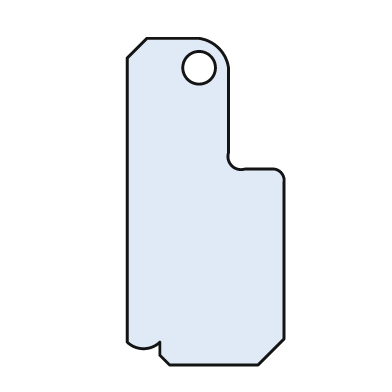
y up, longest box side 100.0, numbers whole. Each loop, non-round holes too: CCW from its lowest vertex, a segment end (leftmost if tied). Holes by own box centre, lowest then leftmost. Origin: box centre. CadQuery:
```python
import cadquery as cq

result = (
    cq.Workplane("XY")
    .moveTo(-11.0, -50.0)
    .lineTo(16.0, -50.0)
    .lineTo(24.0, -42.0)
    .lineTo(24.0, 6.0)
    .threePointArc((23.0, 9.0), (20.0, 10.0))
    .lineTo(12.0, 10.0)
    .threePointArc((8.0, 11.0), (7.0, 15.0))
    .lineTo(7.0, 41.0)
    .threePointArc((4.0, 47.0), (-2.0, 50.0))
    .lineTo(-18.0, 50.0)
    .lineTo(-24.0, 44.0)
    .lineTo(-24.0, -43.0)
    .threePointArc((-19.0, -45.0), (-14.0, -43.0))
    .lineTo(-14.0, -47.0)
    .close()
    .moveTo(-2.0, 41.0)
    .circle(5.0)
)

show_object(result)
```